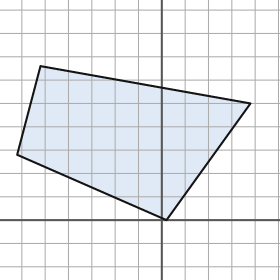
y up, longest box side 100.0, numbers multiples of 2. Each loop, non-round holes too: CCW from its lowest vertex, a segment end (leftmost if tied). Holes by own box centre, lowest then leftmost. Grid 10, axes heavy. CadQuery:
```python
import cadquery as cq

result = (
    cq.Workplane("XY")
    .moveTo(2.0, 0.0)
    .lineTo(38.0, 50.0)
    .lineTo(-52.0, 66.0)
    .lineTo(-62.0, 28.0)
    .close()
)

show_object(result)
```